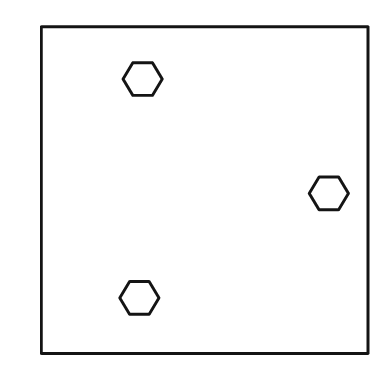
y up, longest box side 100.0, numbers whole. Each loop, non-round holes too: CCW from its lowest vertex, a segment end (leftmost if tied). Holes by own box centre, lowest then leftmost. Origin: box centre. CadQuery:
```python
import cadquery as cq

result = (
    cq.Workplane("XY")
    .moveTo(-50.0, -50.0)
    .lineTo(50.0, -50.0)
    .lineTo(50.0, 50.0)
    .lineTo(-50.0, 50.0)
    .close()
    .moveTo(-23.0, -38.0)
    .lineTo(-17.0, -38.0)
    .lineTo(-14.0, -33.0)
    .lineTo(-17.0, -28.0)
    .lineTo(-23.0, -28.0)
    .lineTo(-26.0, -33.0)
    .close()
    .moveTo(35.0, -6.0)
    .lineTo(41.0, -6.0)
    .lineTo(44.0, -1.0)
    .lineTo(41.0, 4.0)
    .lineTo(35.0, 4.0)
    .lineTo(32.0, -1.0)
    .close()
    .moveTo(-22.0, 29.0)
    .lineTo(-16.0, 29.0)
    .lineTo(-13.0, 34.0)
    .lineTo(-16.0, 39.0)
    .lineTo(-22.0, 39.0)
    .lineTo(-25.0, 34.0)
    .close()
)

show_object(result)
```